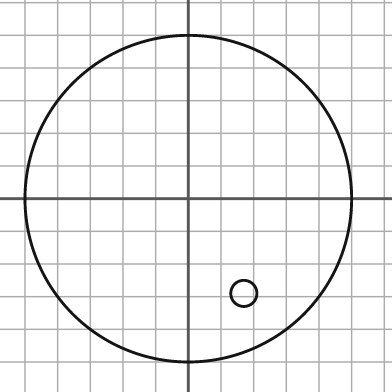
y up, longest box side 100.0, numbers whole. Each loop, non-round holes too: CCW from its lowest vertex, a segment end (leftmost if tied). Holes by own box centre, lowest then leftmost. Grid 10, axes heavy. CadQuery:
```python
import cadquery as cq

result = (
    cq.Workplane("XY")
    .moveTo(0.0, 0.0)
    .circle(50.0)
    .moveTo(17.0, -29.0)
    .circle(4.0)
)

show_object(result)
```